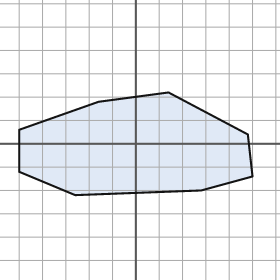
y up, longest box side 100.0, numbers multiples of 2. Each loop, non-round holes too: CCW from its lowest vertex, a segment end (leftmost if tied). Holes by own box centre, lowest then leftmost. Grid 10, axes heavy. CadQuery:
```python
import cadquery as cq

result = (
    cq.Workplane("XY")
    .moveTo(-26.0, -22.0)
    .lineTo(28.0, -20.0)
    .lineTo(50.0, -14.0)
    .lineTo(48.0, 4.0)
    .lineTo(14.0, 22.0)
    .lineTo(-16.0, 18.0)
    .lineTo(-50.0, 6.0)
    .lineTo(-50.0, -12.0)
    .close()
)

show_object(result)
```